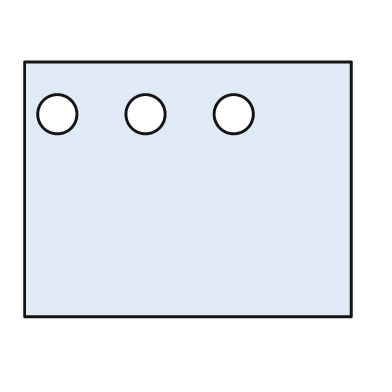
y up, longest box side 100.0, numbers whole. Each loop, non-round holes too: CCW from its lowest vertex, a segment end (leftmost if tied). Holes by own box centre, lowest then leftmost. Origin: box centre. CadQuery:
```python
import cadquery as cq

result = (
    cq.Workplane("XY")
    .moveTo(-50.0, -39.0)
    .lineTo(50.0, -39.0)
    .lineTo(50.0, 39.0)
    .lineTo(-50.0, 39.0)
    .close()
    .moveTo(-40.0, 23.0)
    .circle(6.0)
    .moveTo(-13.0, 23.0)
    .circle(6.0)
    .moveTo(14.0, 23.0)
    .circle(6.0)
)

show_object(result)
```